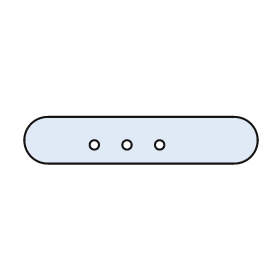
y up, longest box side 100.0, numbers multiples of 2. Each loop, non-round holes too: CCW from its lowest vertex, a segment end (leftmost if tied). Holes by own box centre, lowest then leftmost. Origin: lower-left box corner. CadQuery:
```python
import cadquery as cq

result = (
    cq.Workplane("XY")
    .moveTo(10.0, 0.0)
    .lineTo(90.0, 0.0)
    .threePointArc((100.0, 10.0), (90.0, 20.0))
    .lineTo(10.0, 20.0)
    .threePointArc((0.0, 10.0), (10.0, 0.0))
    .close()
    .moveTo(30.0, 8.0)
    .circle(2.0)
    .moveTo(44.0, 8.0)
    .circle(2.0)
    .moveTo(58.0, 8.0)
    .circle(2.0)
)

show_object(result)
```